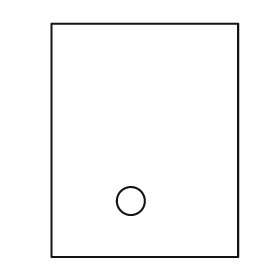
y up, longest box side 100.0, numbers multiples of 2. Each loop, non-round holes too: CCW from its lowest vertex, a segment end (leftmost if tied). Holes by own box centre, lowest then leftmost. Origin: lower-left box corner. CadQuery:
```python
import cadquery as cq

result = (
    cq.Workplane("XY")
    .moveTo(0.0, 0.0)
    .lineTo(80.0, 0.0)
    .lineTo(80.0, 100.0)
    .lineTo(0.0, 100.0)
    .close()
    .moveTo(34.0, 24.0)
    .circle(6.0)
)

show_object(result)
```